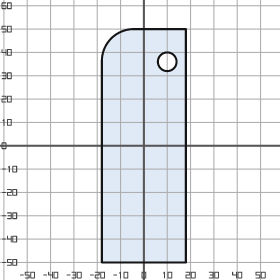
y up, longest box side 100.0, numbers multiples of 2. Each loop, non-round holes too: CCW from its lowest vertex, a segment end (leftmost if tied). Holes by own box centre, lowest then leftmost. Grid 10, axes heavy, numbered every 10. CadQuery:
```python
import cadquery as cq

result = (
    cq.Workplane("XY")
    .moveTo(-18.0, -50.0)
    .lineTo(18.0, -50.0)
    .lineTo(18.0, 50.0)
    .lineTo(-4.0, 50.0)
    .threePointArc((-14.0, 46.0), (-18.0, 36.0))
    .close()
    .moveTo(10.0, 36.0)
    .circle(4.0)
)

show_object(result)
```